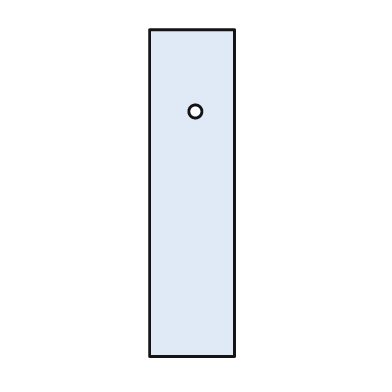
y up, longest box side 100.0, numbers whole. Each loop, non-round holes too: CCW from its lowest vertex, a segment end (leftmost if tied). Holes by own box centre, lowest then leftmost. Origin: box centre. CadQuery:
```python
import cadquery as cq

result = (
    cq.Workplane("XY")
    .moveTo(-13.0, -50.0)
    .lineTo(13.0, -50.0)
    .lineTo(13.0, 50.0)
    .lineTo(-13.0, 50.0)
    .close()
    .moveTo(1.0, 25.0)
    .circle(2.0)
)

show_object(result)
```